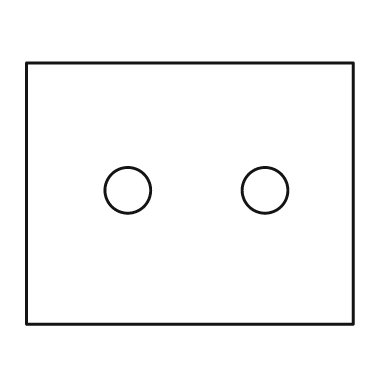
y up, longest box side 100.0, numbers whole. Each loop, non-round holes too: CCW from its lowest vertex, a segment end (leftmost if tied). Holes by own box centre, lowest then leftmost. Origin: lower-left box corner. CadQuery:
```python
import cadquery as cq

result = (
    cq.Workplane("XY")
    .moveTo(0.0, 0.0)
    .lineTo(100.0, 0.0)
    .lineTo(100.0, 80.0)
    .lineTo(0.0, 80.0)
    .close()
    .moveTo(31.0, 41.0)
    .circle(7.0)
    .moveTo(73.0, 41.0)
    .circle(7.0)
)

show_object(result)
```